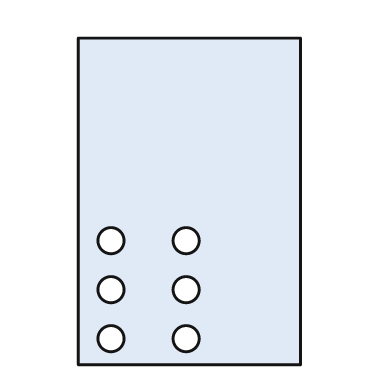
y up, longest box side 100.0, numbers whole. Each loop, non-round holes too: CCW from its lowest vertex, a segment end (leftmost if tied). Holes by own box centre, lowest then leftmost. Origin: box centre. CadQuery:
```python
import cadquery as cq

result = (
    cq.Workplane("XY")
    .moveTo(-34.0, -50.0)
    .lineTo(34.0, -50.0)
    .lineTo(34.0, 50.0)
    .lineTo(-34.0, 50.0)
    .close()
    .moveTo(-24.0, -42.0)
    .circle(4.0)
    .moveTo(-1.0, -42.0)
    .circle(4.0)
    .moveTo(-24.0, -27.0)
    .circle(4.0)
    .moveTo(-1.0, -27.0)
    .circle(4.0)
    .moveTo(-24.0, -12.0)
    .circle(4.0)
    .moveTo(-1.0, -12.0)
    .circle(4.0)
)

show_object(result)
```